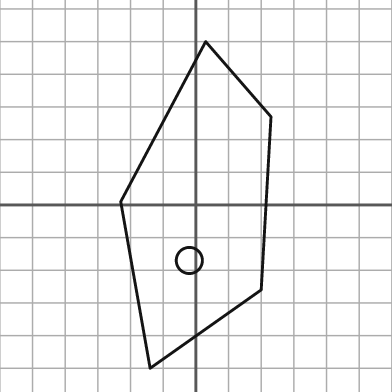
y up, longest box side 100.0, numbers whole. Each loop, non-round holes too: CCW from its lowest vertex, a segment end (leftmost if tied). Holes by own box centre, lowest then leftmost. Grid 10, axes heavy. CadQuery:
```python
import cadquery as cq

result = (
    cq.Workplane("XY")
    .moveTo(-14.0, -50.0)
    .lineTo(20.0, -26.0)
    .lineTo(23.0, 27.0)
    .lineTo(3.0, 50.0)
    .lineTo(-23.0, 1.0)
    .close()
    .moveTo(-2.0, -17.0)
    .circle(4.0)
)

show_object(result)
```